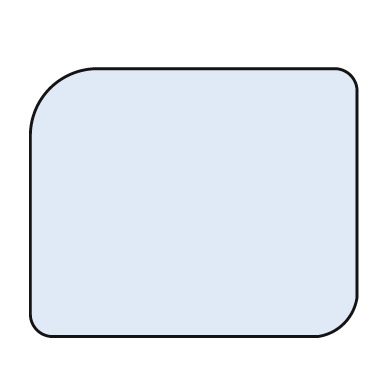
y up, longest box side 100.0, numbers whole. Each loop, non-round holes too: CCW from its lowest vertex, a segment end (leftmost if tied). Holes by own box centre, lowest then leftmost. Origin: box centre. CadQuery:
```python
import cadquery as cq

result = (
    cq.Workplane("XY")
    .moveTo(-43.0, -41.0)
    .lineTo(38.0, -41.0)
    .threePointArc((46.0, -37.0), (50.0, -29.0))
    .lineTo(50.0, 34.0)
    .threePointArc((48.0, 39.0), (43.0, 41.0))
    .lineTo(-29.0, 41.0)
    .threePointArc((-44.0, 35.0), (-50.0, 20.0))
    .lineTo(-50.0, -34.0)
    .threePointArc((-48.0, -39.0), (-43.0, -41.0))
    .close()
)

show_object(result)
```